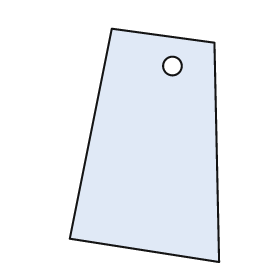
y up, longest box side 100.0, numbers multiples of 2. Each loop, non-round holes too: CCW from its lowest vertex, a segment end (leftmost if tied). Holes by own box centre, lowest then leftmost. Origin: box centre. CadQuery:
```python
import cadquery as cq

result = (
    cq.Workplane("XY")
    .moveTo(32.0, -50.0)
    .lineTo(30.0, 44.0)
    .lineTo(-14.0, 50.0)
    .lineTo(-32.0, -40.0)
    .close()
    .moveTo(12.0, 34.0)
    .circle(4.0)
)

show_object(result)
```